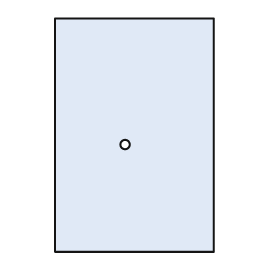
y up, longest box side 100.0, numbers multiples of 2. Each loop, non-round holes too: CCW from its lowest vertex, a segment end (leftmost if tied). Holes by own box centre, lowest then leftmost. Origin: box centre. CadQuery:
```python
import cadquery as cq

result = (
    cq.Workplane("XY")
    .moveTo(-34.0, -50.0)
    .lineTo(34.0, -50.0)
    .lineTo(34.0, 50.0)
    .lineTo(-34.0, 50.0)
    .close()
    .moveTo(-4.0, -4.0)
    .circle(2.0)
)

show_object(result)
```